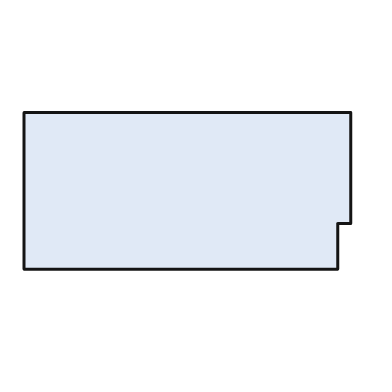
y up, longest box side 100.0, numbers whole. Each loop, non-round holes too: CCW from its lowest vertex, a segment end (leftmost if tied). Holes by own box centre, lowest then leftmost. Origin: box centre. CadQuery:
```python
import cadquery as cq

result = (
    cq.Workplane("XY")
    .moveTo(-50.0, -24.0)
    .lineTo(46.0, -24.0)
    .lineTo(46.0, -10.0)
    .lineTo(50.0, -10.0)
    .lineTo(50.0, 24.0)
    .lineTo(-50.0, 24.0)
    .close()
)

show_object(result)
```